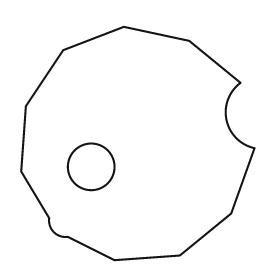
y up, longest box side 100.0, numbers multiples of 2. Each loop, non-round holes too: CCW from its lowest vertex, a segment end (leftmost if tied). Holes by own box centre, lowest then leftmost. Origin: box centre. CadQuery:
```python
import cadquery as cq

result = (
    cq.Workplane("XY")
    .moveTo(-10.0, -50.0)
    .lineTo(18.0, -48.0)
    .lineTo(40.0, -30.0)
    .lineTo(50.0, -2.0)
    .threePointArc((38.0, 10.0), (44.0, 26.0))
    .lineTo(22.0, 44.0)
    .lineTo(-6.0, 50.0)
    .lineTo(-32.0, 40.0)
    .lineTo(-48.0, 16.0)
    .lineTo(-50.0, -12.0)
    .lineTo(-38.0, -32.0)
    .threePointArc((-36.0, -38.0), (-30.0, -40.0))
    .close()
    .moveTo(-20.0, -10.0)
    .circle(10.0)
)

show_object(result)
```